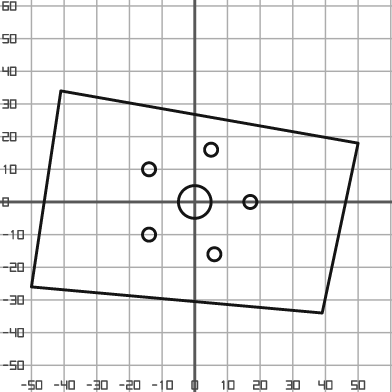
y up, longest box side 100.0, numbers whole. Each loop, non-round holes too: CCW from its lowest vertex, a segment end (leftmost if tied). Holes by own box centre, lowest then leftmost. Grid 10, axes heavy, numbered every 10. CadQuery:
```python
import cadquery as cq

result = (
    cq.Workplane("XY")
    .moveTo(39.0, -34.0)
    .lineTo(50.0, 18.0)
    .lineTo(-41.0, 34.0)
    .lineTo(-50.0, -26.0)
    .close()
    .moveTo(6.0, -16.0)
    .circle(2.0)
    .moveTo(-14.0, -10.0)
    .circle(2.0)
    .moveTo(0.0, 0.0)
    .circle(5.0)
    .moveTo(17.0, 0.0)
    .circle(2.0)
    .moveTo(-14.0, 10.0)
    .circle(2.0)
    .moveTo(5.0, 16.0)
    .circle(2.0)
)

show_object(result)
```